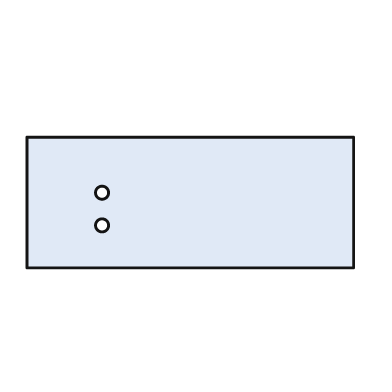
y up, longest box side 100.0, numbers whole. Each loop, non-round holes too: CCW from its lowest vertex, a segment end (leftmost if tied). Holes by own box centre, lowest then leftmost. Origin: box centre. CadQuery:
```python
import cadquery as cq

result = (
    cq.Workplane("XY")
    .moveTo(-50.0, -20.0)
    .lineTo(50.0, -20.0)
    .lineTo(50.0, 20.0)
    .lineTo(-50.0, 20.0)
    .close()
    .moveTo(-27.0, -7.0)
    .circle(2.0)
    .moveTo(-27.0, 3.0)
    .circle(2.0)
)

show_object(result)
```